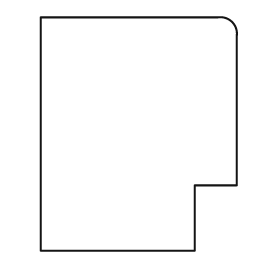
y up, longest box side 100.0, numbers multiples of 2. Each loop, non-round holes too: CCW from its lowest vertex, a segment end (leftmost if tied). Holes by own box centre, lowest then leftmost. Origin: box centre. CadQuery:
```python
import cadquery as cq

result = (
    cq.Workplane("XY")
    .moveTo(-42.0, -50.0)
    .lineTo(24.0, -50.0)
    .lineTo(24.0, -22.0)
    .lineTo(42.0, -22.0)
    .lineTo(42.0, 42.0)
    .threePointArc((40.0, 48.0), (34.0, 50.0))
    .lineTo(-42.0, 50.0)
    .close()
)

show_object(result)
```